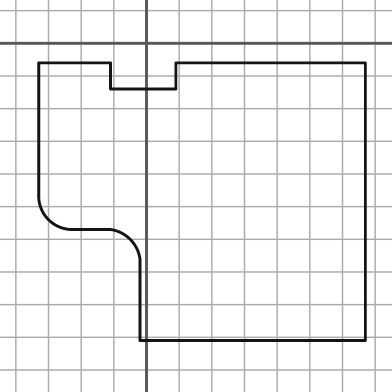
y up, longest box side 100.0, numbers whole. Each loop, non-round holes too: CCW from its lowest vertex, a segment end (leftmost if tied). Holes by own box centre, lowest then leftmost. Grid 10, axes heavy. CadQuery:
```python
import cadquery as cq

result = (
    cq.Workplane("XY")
    .moveTo(-2.0, -91.0)
    .lineTo(67.0, -91.0)
    .lineTo(67.0, -6.0)
    .lineTo(9.0, -6.0)
    .lineTo(9.0, -14.0)
    .lineTo(-11.0, -14.0)
    .lineTo(-11.0, -6.0)
    .lineTo(-33.0, -6.0)
    .lineTo(-33.0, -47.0)
    .threePointArc((-30.0, -54.0), (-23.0, -57.0))
    .lineTo(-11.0, -57.0)
    .threePointArc((-5.0, -60.0), (-2.0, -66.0))
    .close()
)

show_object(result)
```